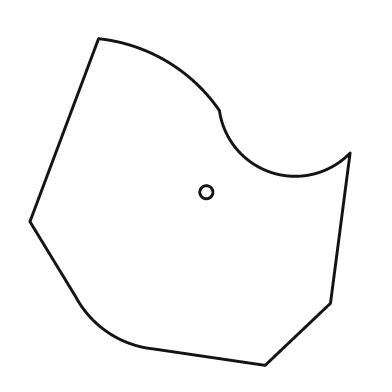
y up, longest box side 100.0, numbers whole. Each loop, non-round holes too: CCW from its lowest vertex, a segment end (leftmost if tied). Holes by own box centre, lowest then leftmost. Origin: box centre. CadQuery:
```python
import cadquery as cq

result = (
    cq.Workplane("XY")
    .moveTo(23.0, -50.0)
    .lineTo(43.0, -31.0)
    .lineTo(49.0, 15.0)
    .threePointArc((25.0, 9.0), (9.0, 28.0))
    .threePointArc((-7.0, 43.0), (-28.0, 50.0))
    .lineTo(-49.0, -6.0)
    .lineTo(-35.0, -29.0)
    .threePointArc((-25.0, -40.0), (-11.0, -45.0))
    .close()
    .moveTo(5.0, 3.0)
    .circle(2.0)
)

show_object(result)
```